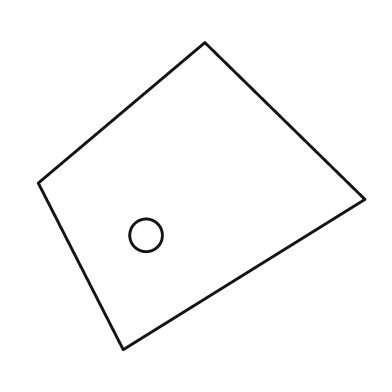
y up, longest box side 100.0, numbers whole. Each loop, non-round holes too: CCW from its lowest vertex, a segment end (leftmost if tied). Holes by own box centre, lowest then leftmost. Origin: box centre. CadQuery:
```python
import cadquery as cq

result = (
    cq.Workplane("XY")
    .moveTo(-24.0, -47.0)
    .lineTo(50.0, -1.0)
    .lineTo(1.0, 47.0)
    .lineTo(-50.0, 4.0)
    .close()
    .moveTo(-17.0, -12.0)
    .circle(5.0)
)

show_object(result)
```